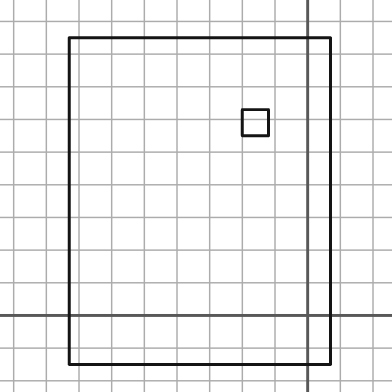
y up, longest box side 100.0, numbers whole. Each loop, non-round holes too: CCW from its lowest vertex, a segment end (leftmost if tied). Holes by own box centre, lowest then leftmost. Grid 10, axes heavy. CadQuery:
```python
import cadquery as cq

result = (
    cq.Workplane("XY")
    .moveTo(-73.0, -15.0)
    .lineTo(7.0, -15.0)
    .lineTo(7.0, 85.0)
    .lineTo(-73.0, 85.0)
    .close()
    .moveTo(-20.0, 55.0)
    .lineTo(-12.0, 55.0)
    .lineTo(-12.0, 63.0)
    .lineTo(-20.0, 63.0)
    .close()
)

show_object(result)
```